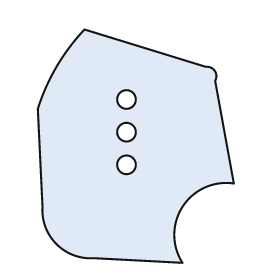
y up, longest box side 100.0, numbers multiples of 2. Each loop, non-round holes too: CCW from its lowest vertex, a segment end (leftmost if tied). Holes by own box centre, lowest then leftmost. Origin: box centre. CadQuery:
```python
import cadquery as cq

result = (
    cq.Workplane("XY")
    .moveTo(20.0, -50.0)
    .threePointArc((20.0, -26.0), (42.0, -16.0))
    .lineTo(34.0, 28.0)
    .threePointArc((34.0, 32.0), (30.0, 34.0))
    .lineTo(-22.0, 50.0)
    .threePointArc((-34.0, 34.0), (-42.0, 16.0))
    .lineTo(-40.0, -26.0)
    .threePointArc((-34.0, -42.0), (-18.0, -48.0))
    .close()
    .moveTo(-4.0, -8.0)
    .circle(4.0)
    .moveTo(-4.0, 6.0)
    .circle(4.0)
    .moveTo(-4.0, 20.0)
    .circle(4.0)
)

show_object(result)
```